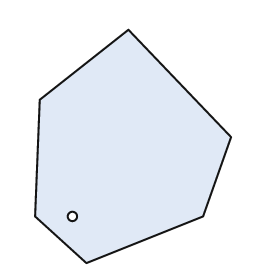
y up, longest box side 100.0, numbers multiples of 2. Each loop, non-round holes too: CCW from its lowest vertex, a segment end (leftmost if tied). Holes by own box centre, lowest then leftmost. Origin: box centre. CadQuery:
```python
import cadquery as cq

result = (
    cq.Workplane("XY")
    .moveTo(-20.0, -50.0)
    .lineTo(30.0, -30.0)
    .lineTo(42.0, 4.0)
    .lineTo(-2.0, 50.0)
    .lineTo(-40.0, 20.0)
    .lineTo(-42.0, -30.0)
    .close()
    .moveTo(-26.0, -30.0)
    .circle(2.0)
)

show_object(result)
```